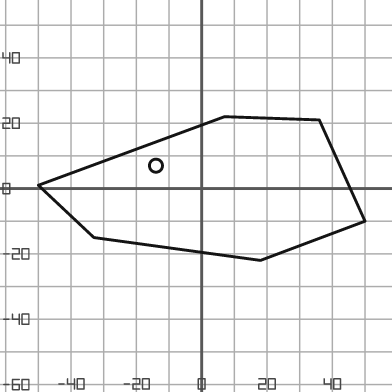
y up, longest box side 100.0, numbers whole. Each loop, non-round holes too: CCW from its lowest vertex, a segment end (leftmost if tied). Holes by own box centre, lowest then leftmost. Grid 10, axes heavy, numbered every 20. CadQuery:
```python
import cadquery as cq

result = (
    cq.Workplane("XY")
    .moveTo(18.0, -22.0)
    .lineTo(50.0, -10.0)
    .lineTo(36.0, 21.0)
    .lineTo(7.0, 22.0)
    .lineTo(-50.0, 1.0)
    .lineTo(-33.0, -15.0)
    .close()
    .moveTo(-14.0, 7.0)
    .circle(2.0)
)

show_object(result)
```